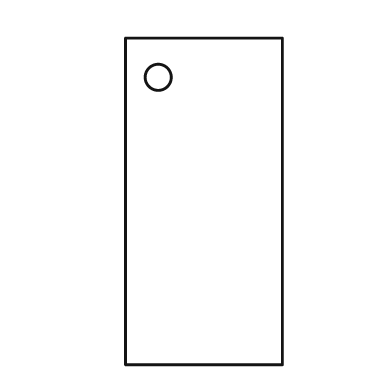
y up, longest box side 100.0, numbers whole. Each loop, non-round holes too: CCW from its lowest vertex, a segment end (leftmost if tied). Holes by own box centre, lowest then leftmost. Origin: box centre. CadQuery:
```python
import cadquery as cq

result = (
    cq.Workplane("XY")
    .moveTo(-24.0, -50.0)
    .lineTo(24.0, -50.0)
    .lineTo(24.0, 50.0)
    .lineTo(-24.0, 50.0)
    .close()
    .moveTo(-14.0, 38.0)
    .circle(4.0)
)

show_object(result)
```